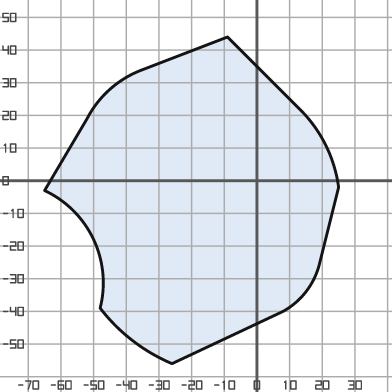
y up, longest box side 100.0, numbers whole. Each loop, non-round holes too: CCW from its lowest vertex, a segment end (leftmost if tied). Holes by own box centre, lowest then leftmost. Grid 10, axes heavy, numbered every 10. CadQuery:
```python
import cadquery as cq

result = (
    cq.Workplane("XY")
    .moveTo(-26.0, -56.0)
    .lineTo(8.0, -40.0)
    .threePointArc((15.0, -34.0), (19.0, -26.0))
    .lineTo(25.0, -2.0)
    .threePointArc((21.0, 11.0), (13.0, 22.0))
    .lineTo(-9.0, 44.0)
    .lineTo(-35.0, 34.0)
    .threePointArc((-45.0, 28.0), (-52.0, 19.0))
    .lineTo(-65.0, -3.0)
    .threePointArc((-50.0, -18.0), (-48.0, -39.0))
    .threePointArc((-38.0, -49.0), (-26.0, -56.0))
    .close()
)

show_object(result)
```